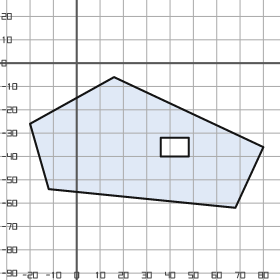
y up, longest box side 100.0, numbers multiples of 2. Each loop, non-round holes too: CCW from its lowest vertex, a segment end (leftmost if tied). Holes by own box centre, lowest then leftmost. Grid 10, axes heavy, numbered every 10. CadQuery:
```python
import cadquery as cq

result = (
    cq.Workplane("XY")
    .moveTo(68.0, -62.0)
    .lineTo(80.0, -36.0)
    .lineTo(16.0, -6.0)
    .lineTo(-20.0, -26.0)
    .lineTo(-12.0, -54.0)
    .close()
    .moveTo(36.0, -40.0)
    .lineTo(48.0, -40.0)
    .lineTo(48.0, -32.0)
    .lineTo(36.0, -32.0)
    .close()
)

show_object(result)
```